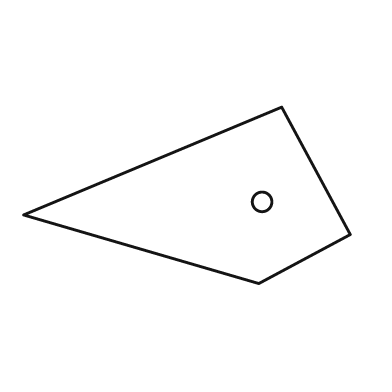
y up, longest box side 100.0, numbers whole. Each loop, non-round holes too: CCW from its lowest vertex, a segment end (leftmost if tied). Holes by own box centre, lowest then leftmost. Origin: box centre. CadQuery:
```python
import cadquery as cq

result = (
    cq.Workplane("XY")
    .moveTo(22.0, -27.0)
    .lineTo(50.0, -12.0)
    .lineTo(29.0, 27.0)
    .lineTo(-50.0, -6.0)
    .close()
    .moveTo(23.0, -2.0)
    .circle(3.0)
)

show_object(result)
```